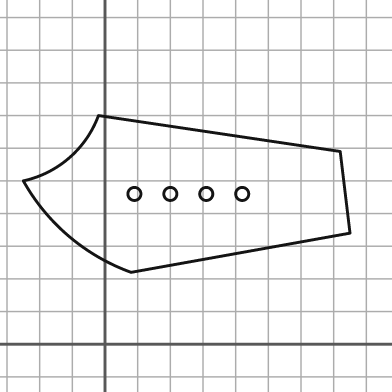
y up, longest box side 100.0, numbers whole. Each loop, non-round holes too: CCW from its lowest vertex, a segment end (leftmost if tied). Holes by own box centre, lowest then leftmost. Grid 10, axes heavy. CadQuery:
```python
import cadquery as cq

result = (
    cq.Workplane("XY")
    .moveTo(8.0, 22.0)
    .lineTo(75.0, 34.0)
    .lineTo(72.0, 59.0)
    .lineTo(-2.0, 70.0)
    .threePointArc((-11.0, 57.0), (-25.0, 50.0))
    .threePointArc((-11.0, 33.0), (8.0, 22.0))
    .close()
    .moveTo(9.0, 46.0)
    .circle(2.0)
    .moveTo(20.0, 46.0)
    .circle(2.0)
    .moveTo(31.0, 46.0)
    .circle(2.0)
    .moveTo(42.0, 46.0)
    .circle(2.0)
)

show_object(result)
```